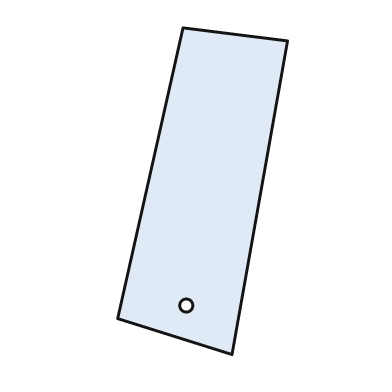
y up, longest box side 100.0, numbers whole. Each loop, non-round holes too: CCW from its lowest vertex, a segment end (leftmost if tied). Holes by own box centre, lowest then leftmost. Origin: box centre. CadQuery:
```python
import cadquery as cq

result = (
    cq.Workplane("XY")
    .moveTo(9.0, -50.0)
    .lineTo(26.0, 46.0)
    .lineTo(-6.0, 50.0)
    .lineTo(-26.0, -39.0)
    .close()
    .moveTo(-5.0, -35.0)
    .circle(2.0)
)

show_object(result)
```